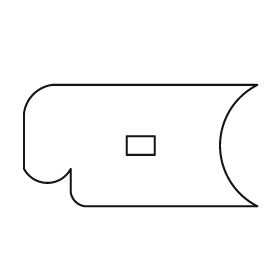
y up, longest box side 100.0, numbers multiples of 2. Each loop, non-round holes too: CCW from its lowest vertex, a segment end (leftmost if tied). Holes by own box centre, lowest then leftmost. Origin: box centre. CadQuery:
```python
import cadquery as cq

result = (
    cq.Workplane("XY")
    .moveTo(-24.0, -26.0)
    .lineTo(50.0, -26.0)
    .threePointArc((34.0, 0.0), (50.0, 26.0))
    .lineTo(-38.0, 26.0)
    .threePointArc((-46.0, 22.0), (-50.0, 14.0))
    .lineTo(-50.0, -10.0)
    .threePointArc((-40.0, -16.0), (-30.0, -10.0))
    .lineTo(-30.0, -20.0)
    .threePointArc((-28.0, -24.0), (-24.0, -26.0))
    .close()
    .moveTo(-6.0, -4.0)
    .lineTo(6.0, -4.0)
    .lineTo(6.0, 4.0)
    .lineTo(-6.0, 4.0)
    .close()
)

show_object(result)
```